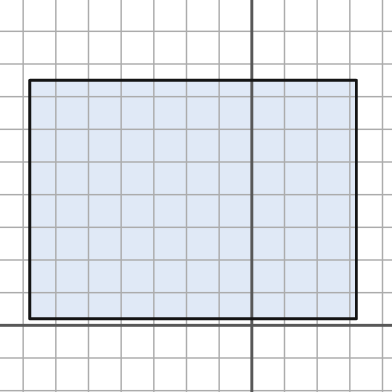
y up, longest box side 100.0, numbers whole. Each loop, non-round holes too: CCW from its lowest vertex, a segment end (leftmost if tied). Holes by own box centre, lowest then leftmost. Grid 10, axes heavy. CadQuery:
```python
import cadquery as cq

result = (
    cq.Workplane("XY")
    .moveTo(-68.0, 2.0)
    .lineTo(32.0, 2.0)
    .lineTo(32.0, 75.0)
    .lineTo(-68.0, 75.0)
    .close()
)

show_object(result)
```